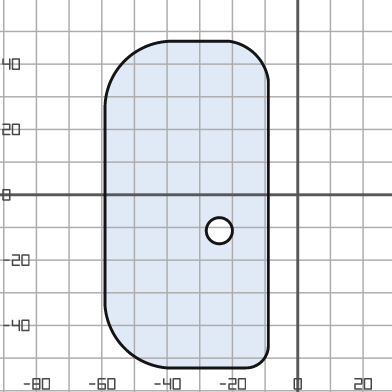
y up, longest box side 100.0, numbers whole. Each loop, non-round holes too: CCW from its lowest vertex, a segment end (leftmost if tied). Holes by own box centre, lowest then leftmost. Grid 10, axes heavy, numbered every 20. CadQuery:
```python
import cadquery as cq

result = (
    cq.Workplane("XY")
    .moveTo(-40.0, -53.0)
    .lineTo(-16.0, -53.0)
    .threePointArc((-11.0, -51.0), (-9.0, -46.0))
    .lineTo(-9.0, 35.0)
    .threePointArc((-13.0, 43.0), (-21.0, 47.0))
    .lineTo(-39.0, 47.0)
    .threePointArc((-53.0, 41.0), (-59.0, 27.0))
    .lineTo(-59.0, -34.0)
    .threePointArc((-53.0, -47.0), (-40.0, -53.0))
    .close()
    .moveTo(-24.0, -11.0)
    .circle(4.0)
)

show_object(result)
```